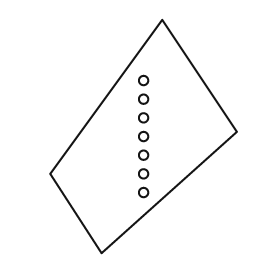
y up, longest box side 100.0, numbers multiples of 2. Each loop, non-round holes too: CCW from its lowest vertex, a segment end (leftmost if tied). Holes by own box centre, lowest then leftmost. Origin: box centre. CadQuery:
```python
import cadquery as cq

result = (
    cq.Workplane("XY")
    .moveTo(-18.0, -50.0)
    .lineTo(40.0, 2.0)
    .lineTo(8.0, 50.0)
    .lineTo(-40.0, -16.0)
    .close()
    .moveTo(0.0, -24.0)
    .circle(2.0)
    .moveTo(0.0, -16.0)
    .circle(2.0)
    .moveTo(0.0, -8.0)
    .circle(2.0)
    .moveTo(0.0, 0.0)
    .circle(2.0)
    .moveTo(0.0, 8.0)
    .circle(2.0)
    .moveTo(0.0, 16.0)
    .circle(2.0)
    .moveTo(0.0, 24.0)
    .circle(2.0)
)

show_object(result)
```